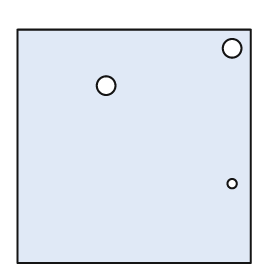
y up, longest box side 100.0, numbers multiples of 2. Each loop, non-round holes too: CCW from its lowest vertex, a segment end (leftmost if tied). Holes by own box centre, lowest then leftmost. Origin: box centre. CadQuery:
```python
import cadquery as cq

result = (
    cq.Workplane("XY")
    .moveTo(-50.0, -50.0)
    .lineTo(50.0, -50.0)
    .lineTo(50.0, 50.0)
    .lineTo(-50.0, 50.0)
    .close()
    .moveTo(42.0, -16.0)
    .circle(2.0)
    .moveTo(-12.0, 26.0)
    .circle(4.0)
    .moveTo(42.0, 42.0)
    .circle(4.0)
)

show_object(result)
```